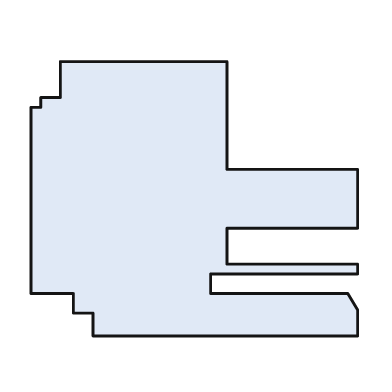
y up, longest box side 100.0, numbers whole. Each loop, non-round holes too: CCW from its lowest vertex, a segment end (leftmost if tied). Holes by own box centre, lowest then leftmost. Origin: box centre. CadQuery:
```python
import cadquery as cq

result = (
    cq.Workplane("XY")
    .moveTo(-31.0, -42.0)
    .lineTo(50.0, -42.0)
    .lineTo(50.0, -34.0)
    .lineTo(47.0, -29.0)
    .lineTo(5.0, -29.0)
    .lineTo(5.0, -23.0)
    .lineTo(50.0, -23.0)
    .lineTo(50.0, -20.0)
    .lineTo(10.0, -20.0)
    .lineTo(10.0, -9.0)
    .lineTo(50.0, -9.0)
    .lineTo(50.0, 9.0)
    .lineTo(10.0, 9.0)
    .lineTo(10.0, 42.0)
    .lineTo(-41.0, 42.0)
    .lineTo(-41.0, 31.0)
    .lineTo(-47.0, 31.0)
    .lineTo(-47.0, 28.0)
    .lineTo(-50.0, 28.0)
    .lineTo(-50.0, -29.0)
    .lineTo(-37.0, -29.0)
    .lineTo(-37.0, -35.0)
    .lineTo(-31.0, -35.0)
    .close()
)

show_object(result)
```